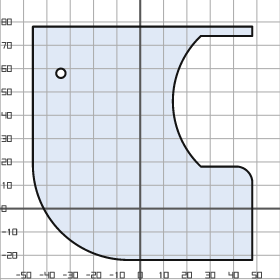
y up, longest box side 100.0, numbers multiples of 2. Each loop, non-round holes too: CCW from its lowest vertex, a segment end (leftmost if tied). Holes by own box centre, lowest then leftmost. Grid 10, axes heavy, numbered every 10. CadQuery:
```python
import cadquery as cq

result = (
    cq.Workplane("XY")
    .moveTo(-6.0, -22.0)
    .lineTo(48.0, -22.0)
    .lineTo(48.0, 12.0)
    .threePointArc((46.0, 16.0), (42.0, 18.0))
    .lineTo(26.0, 18.0)
    .threePointArc((14.0, 46.0), (26.0, 74.0))
    .lineTo(48.0, 74.0)
    .lineTo(48.0, 78.0)
    .lineTo(-46.0, 78.0)
    .lineTo(-46.0, 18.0)
    .threePointArc((-34.0, -10.0), (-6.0, -22.0))
    .close()
    .moveTo(-34.0, 58.0)
    .circle(2.0)
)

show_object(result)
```